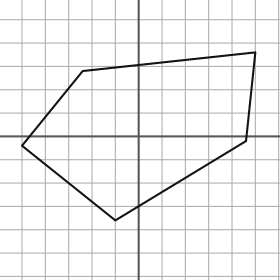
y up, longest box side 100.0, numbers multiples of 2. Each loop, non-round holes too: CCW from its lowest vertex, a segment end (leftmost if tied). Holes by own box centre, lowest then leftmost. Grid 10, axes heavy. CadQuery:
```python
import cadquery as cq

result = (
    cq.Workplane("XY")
    .moveTo(-10.0, -36.0)
    .lineTo(46.0, -2.0)
    .lineTo(50.0, 36.0)
    .lineTo(-24.0, 28.0)
    .lineTo(-50.0, -4.0)
    .close()
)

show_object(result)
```